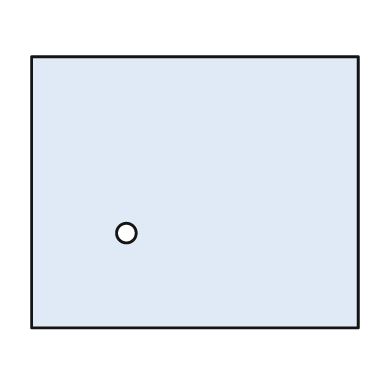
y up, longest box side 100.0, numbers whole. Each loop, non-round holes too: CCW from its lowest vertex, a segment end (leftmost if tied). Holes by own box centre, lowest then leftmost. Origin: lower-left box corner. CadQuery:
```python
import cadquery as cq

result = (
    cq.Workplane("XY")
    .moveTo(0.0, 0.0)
    .lineTo(100.0, 0.0)
    .lineTo(100.0, 83.0)
    .lineTo(0.0, 83.0)
    .close()
    .moveTo(29.0, 29.0)
    .circle(3.0)
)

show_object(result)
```